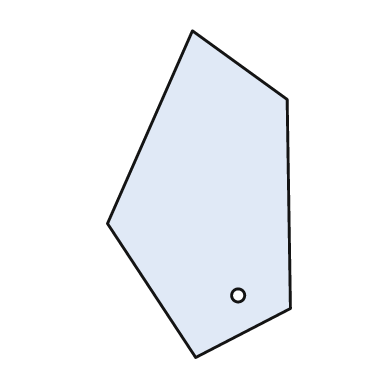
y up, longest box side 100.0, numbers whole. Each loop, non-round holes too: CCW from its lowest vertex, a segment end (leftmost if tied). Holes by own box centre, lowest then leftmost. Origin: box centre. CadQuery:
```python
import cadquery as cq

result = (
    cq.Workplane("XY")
    .moveTo(-1.0, -50.0)
    .lineTo(28.0, -35.0)
    .lineTo(27.0, 29.0)
    .lineTo(-2.0, 50.0)
    .lineTo(-28.0, -9.0)
    .close()
    .moveTo(12.0, -31.0)
    .circle(2.0)
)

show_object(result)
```